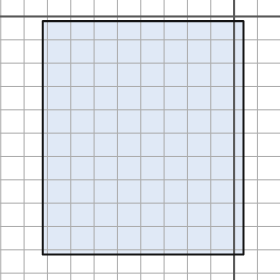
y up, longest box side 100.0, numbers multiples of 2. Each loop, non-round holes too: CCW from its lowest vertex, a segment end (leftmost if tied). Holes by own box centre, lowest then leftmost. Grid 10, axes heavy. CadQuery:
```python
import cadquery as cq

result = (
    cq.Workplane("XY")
    .moveTo(-82.0, -102.0)
    .lineTo(4.0, -102.0)
    .lineTo(4.0, -2.0)
    .lineTo(-82.0, -2.0)
    .close()
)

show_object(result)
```